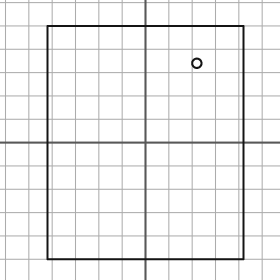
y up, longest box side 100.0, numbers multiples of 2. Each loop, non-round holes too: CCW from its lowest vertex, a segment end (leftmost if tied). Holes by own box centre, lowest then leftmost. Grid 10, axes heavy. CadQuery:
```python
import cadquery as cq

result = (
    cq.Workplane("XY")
    .moveTo(-42.0, -50.0)
    .lineTo(42.0, -50.0)
    .lineTo(42.0, 50.0)
    .lineTo(-42.0, 50.0)
    .close()
    .moveTo(22.0, 34.0)
    .circle(2.0)
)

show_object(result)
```